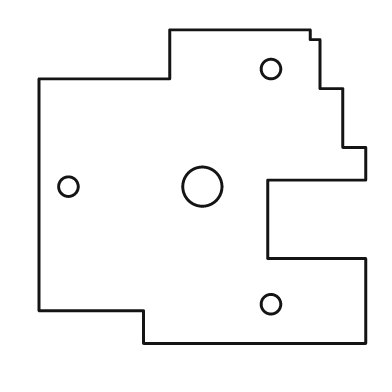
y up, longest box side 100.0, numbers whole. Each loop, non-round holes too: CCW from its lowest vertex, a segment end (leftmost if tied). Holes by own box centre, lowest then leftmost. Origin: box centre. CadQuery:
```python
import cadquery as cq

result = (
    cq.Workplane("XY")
    .moveTo(-18.0, -48.0)
    .lineTo(50.0, -48.0)
    .lineTo(50.0, -22.0)
    .lineTo(20.0, -22.0)
    .lineTo(20.0, 2.0)
    .lineTo(50.0, 2.0)
    .lineTo(50.0, 12.0)
    .lineTo(43.0, 12.0)
    .lineTo(43.0, 30.0)
    .lineTo(36.0, 30.0)
    .lineTo(36.0, 45.0)
    .lineTo(33.0, 45.0)
    .lineTo(33.0, 48.0)
    .lineTo(-10.0, 48.0)
    .lineTo(-10.0, 33.0)
    .lineTo(-50.0, 33.0)
    .lineTo(-50.0, -38.0)
    .lineTo(-18.0, -38.0)
    .close()
    .moveTo(21.0, -36.0)
    .circle(3.0)
    .moveTo(-41.0, 0.0)
    .circle(3.0)
    .moveTo(0.0, 0.0)
    .circle(6.0)
    .moveTo(21.0, 36.0)
    .circle(3.0)
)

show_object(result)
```